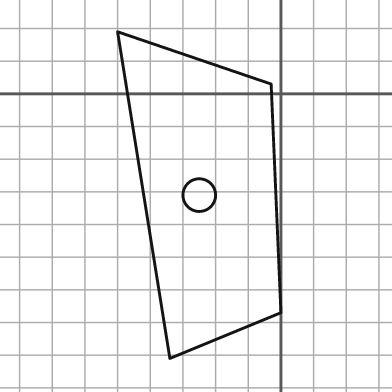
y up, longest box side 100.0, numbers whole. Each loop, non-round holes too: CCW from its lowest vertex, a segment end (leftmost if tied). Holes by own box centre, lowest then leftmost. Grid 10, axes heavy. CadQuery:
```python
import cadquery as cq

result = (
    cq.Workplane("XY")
    .moveTo(-34.0, -81.0)
    .lineTo(0.0, -67.0)
    .lineTo(-3.0, 3.0)
    .lineTo(-50.0, 19.0)
    .close()
    .moveTo(-25.0, -31.0)
    .circle(5.0)
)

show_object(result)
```